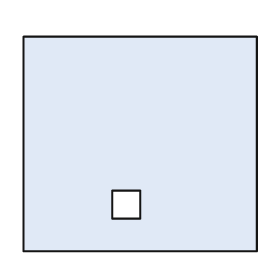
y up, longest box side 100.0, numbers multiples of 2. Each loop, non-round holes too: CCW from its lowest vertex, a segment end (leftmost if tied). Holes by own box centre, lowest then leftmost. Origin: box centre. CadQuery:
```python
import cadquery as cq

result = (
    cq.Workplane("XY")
    .moveTo(-50.0, -46.0)
    .lineTo(50.0, -46.0)
    .lineTo(50.0, 46.0)
    .lineTo(-50.0, 46.0)
    .close()
    .moveTo(-12.0, -32.0)
    .lineTo(0.0, -32.0)
    .lineTo(0.0, -20.0)
    .lineTo(-12.0, -20.0)
    .close()
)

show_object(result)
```